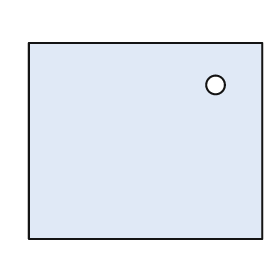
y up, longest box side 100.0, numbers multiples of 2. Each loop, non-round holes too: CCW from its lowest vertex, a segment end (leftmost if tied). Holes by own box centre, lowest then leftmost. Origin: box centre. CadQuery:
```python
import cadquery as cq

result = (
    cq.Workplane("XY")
    .moveTo(-50.0, -42.0)
    .lineTo(50.0, -42.0)
    .lineTo(50.0, 42.0)
    .lineTo(-50.0, 42.0)
    .close()
    .moveTo(30.0, 24.0)
    .circle(4.0)
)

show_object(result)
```